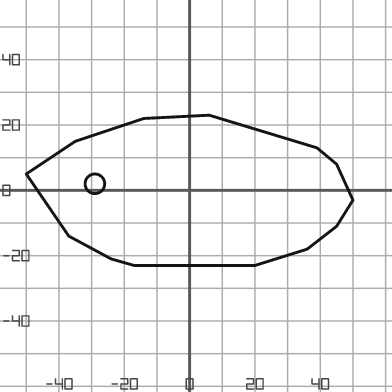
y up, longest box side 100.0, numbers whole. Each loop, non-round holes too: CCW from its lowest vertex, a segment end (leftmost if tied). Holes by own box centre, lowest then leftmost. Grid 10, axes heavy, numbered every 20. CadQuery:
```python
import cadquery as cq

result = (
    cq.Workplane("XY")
    .moveTo(-17.0, -23.0)
    .lineTo(20.0, -23.0)
    .lineTo(36.0, -18.0)
    .lineTo(45.0, -11.0)
    .lineTo(50.0, -3.0)
    .lineTo(45.0, 8.0)
    .lineTo(39.0, 13.0)
    .lineTo(6.0, 23.0)
    .lineTo(-14.0, 22.0)
    .lineTo(-35.0, 15.0)
    .lineTo(-50.0, 5.0)
    .lineTo(-37.0, -14.0)
    .lineTo(-24.0, -21.0)
    .close()
    .moveTo(-29.0, 2.0)
    .circle(3.0)
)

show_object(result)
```